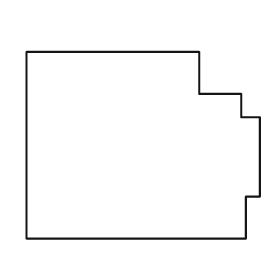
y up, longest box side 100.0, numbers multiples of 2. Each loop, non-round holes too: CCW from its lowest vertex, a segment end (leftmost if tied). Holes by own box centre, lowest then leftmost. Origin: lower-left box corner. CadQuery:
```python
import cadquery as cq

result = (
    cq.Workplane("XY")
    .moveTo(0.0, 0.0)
    .lineTo(94.0, 0.0)
    .lineTo(94.0, 18.0)
    .lineTo(100.0, 18.0)
    .lineTo(100.0, 52.0)
    .lineTo(92.0, 52.0)
    .lineTo(92.0, 62.0)
    .lineTo(74.0, 62.0)
    .lineTo(74.0, 80.0)
    .lineTo(0.0, 80.0)
    .close()
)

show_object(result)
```